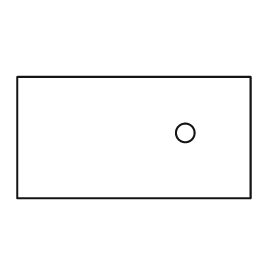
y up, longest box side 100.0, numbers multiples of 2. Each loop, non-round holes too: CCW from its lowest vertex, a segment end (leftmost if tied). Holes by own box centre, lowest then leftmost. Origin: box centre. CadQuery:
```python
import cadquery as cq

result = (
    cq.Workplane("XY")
    .moveTo(-50.0, -26.0)
    .lineTo(50.0, -26.0)
    .lineTo(50.0, 26.0)
    .lineTo(-50.0, 26.0)
    .close()
    .moveTo(22.0, 2.0)
    .circle(4.0)
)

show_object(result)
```